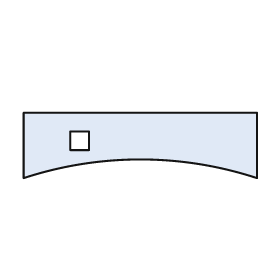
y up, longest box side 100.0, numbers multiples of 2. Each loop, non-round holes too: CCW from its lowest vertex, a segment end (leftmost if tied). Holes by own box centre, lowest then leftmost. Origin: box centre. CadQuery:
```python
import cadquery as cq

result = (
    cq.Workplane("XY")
    .moveTo(-50.0, -14.0)
    .threePointArc((0.0, -6.0), (50.0, -14.0))
    .lineTo(50.0, 14.0)
    .lineTo(-50.0, 14.0)
    .close()
    .moveTo(-30.0, -2.0)
    .lineTo(-22.0, -2.0)
    .lineTo(-22.0, 6.0)
    .lineTo(-30.0, 6.0)
    .close()
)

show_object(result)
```